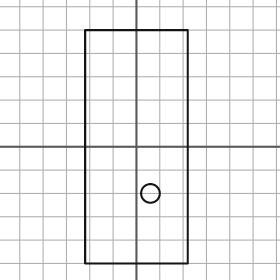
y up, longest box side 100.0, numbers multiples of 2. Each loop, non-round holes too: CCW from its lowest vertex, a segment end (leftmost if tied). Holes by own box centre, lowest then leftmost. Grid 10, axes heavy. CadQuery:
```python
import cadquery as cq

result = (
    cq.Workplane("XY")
    .moveTo(-22.0, -50.0)
    .lineTo(22.0, -50.0)
    .lineTo(22.0, 50.0)
    .lineTo(-22.0, 50.0)
    .close()
    .moveTo(6.0, -20.0)
    .circle(4.0)
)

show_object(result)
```